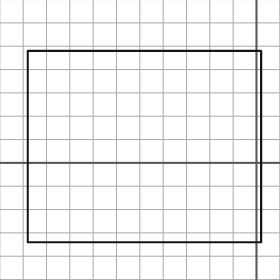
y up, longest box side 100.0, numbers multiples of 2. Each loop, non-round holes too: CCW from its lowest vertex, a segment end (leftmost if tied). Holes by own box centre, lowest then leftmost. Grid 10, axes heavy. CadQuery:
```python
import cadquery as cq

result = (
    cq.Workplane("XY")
    .moveTo(-98.0, -34.0)
    .lineTo(2.0, -34.0)
    .lineTo(2.0, 48.0)
    .lineTo(-98.0, 48.0)
    .close()
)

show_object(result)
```